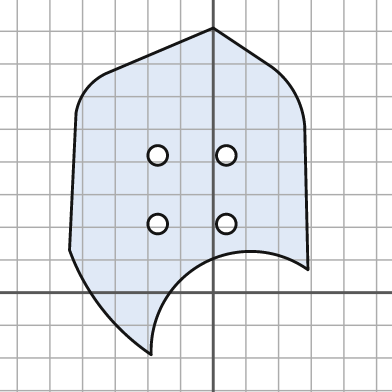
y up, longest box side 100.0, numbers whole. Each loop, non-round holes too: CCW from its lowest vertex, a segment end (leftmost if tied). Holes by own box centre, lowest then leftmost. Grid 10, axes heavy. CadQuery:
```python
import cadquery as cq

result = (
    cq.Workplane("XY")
    .moveTo(-19.0, -19.0)
    .threePointArc((-3.0, 9.0), (29.0, 7.0))
    .lineTo(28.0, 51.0)
    .threePointArc((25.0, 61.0), (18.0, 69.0))
    .lineTo(0.0, 81.0)
    .lineTo(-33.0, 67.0)
    .threePointArc((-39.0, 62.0), (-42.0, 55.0))
    .lineTo(-44.0, 13.0)
    .threePointArc((-34.0, -5.0), (-19.0, -19.0))
    .close()
    .moveTo(-17.0, 21.0)
    .circle(3.0)
    .moveTo(4.0, 21.0)
    .circle(3.0)
    .moveTo(-17.0, 42.0)
    .circle(3.0)
    .moveTo(4.0, 42.0)
    .circle(3.0)
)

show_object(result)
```